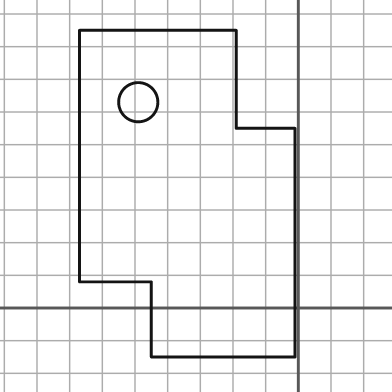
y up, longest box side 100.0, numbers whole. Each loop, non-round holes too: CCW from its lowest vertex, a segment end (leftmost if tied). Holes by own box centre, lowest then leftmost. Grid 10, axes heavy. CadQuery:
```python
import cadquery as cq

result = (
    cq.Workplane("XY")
    .moveTo(-45.0, -15.0)
    .lineTo(-1.0, -15.0)
    .lineTo(-1.0, 55.0)
    .lineTo(-19.0, 55.0)
    .lineTo(-19.0, 85.0)
    .lineTo(-67.0, 85.0)
    .lineTo(-67.0, 8.0)
    .lineTo(-45.0, 8.0)
    .close()
    .moveTo(-49.0, 63.0)
    .circle(6.0)
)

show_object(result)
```